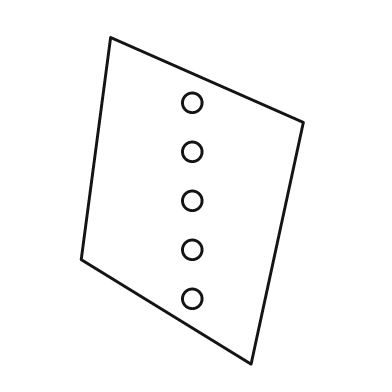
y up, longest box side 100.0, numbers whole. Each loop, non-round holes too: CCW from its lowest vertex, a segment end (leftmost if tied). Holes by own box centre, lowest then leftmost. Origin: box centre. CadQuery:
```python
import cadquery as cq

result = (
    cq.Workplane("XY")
    .moveTo(18.0, -50.0)
    .lineTo(34.0, 24.0)
    .lineTo(-25.0, 50.0)
    .lineTo(-34.0, -18.0)
    .close()
    .moveTo(0.0, -30.0)
    .circle(3.0)
    .moveTo(0.0, -15.0)
    .circle(3.0)
    .moveTo(0.0, 0.0)
    .circle(3.0)
    .moveTo(0.0, 15.0)
    .circle(3.0)
    .moveTo(0.0, 30.0)
    .circle(3.0)
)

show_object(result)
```